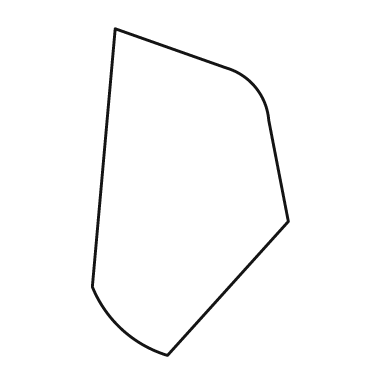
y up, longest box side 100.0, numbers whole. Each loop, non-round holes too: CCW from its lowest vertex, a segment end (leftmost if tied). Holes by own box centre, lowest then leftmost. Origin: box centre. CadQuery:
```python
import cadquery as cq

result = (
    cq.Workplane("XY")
    .moveTo(-7.0, -50.0)
    .lineTo(30.0, -9.0)
    .lineTo(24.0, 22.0)
    .threePointArc((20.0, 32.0), (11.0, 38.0))
    .lineTo(-23.0, 50.0)
    .lineTo(-30.0, -29.0)
    .threePointArc((-21.0, -42.0), (-7.0, -50.0))
    .close()
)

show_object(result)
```